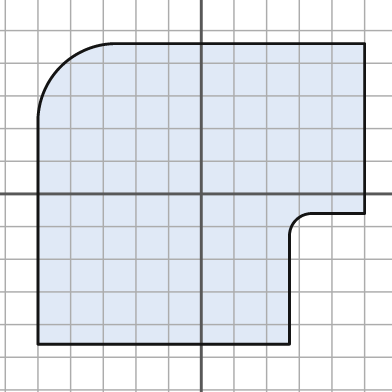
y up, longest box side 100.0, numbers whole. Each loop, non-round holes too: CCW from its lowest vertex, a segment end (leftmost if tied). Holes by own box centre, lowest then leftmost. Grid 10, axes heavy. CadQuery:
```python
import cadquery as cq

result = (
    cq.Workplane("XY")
    .moveTo(-50.0, -46.0)
    .lineTo(27.0, -46.0)
    .lineTo(27.0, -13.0)
    .threePointArc((29.0, -8.0), (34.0, -6.0))
    .lineTo(50.0, -6.0)
    .lineTo(50.0, 46.0)
    .lineTo(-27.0, 46.0)
    .threePointArc((-43.0, 39.0), (-50.0, 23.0))
    .close()
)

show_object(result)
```